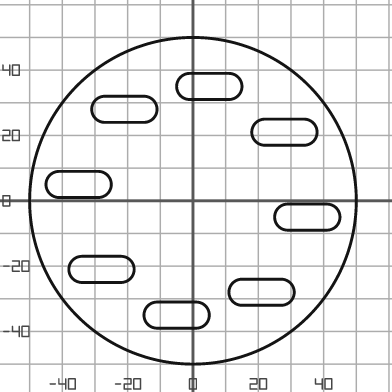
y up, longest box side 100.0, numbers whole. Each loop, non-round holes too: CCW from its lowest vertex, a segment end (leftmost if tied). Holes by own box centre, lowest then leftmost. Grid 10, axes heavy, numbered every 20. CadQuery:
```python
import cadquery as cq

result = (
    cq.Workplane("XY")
    .moveTo(0.0, 0.0)
    .circle(50.0)
    .moveTo(-11.0, -39.0)
    .lineTo(1.0, -39.0)
    .threePointArc((5.0, -35.0), (1.0, -31.0))
    .lineTo(-11.0, -31.0)
    .threePointArc((-15.0, -35.0), (-11.0, -39.0))
    .close()
    .moveTo(15.0, -32.0)
    .lineTo(27.0, -32.0)
    .threePointArc((31.0, -28.0), (27.0, -24.0))
    .lineTo(15.0, -24.0)
    .threePointArc((11.0, -28.0), (15.0, -32.0))
    .close()
    .moveTo(-34.0, -25.0)
    .lineTo(-22.0, -25.0)
    .threePointArc((-18.0, -21.0), (-22.0, -17.0))
    .lineTo(-34.0, -17.0)
    .threePointArc((-38.0, -21.0), (-34.0, -25.0))
    .close()
    .moveTo(29.0, -9.0)
    .lineTo(41.0, -9.0)
    .threePointArc((45.0, -5.0), (41.0, -1.0))
    .lineTo(29.0, -1.0)
    .threePointArc((25.0, -5.0), (29.0, -9.0))
    .close()
    .moveTo(-41.0, 1.0)
    .lineTo(-29.0, 1.0)
    .threePointArc((-25.0, 5.0), (-29.0, 9.0))
    .lineTo(-41.0, 9.0)
    .threePointArc((-45.0, 5.0), (-41.0, 1.0))
    .close()
    .moveTo(22.0, 17.0)
    .lineTo(34.0, 17.0)
    .threePointArc((38.0, 21.0), (34.0, 25.0))
    .lineTo(22.0, 25.0)
    .threePointArc((18.0, 21.0), (22.0, 17.0))
    .close()
    .moveTo(-27.0, 24.0)
    .lineTo(-15.0, 24.0)
    .threePointArc((-11.0, 28.0), (-15.0, 32.0))
    .lineTo(-27.0, 32.0)
    .threePointArc((-31.0, 28.0), (-27.0, 24.0))
    .close()
    .moveTo(-1.0, 31.0)
    .lineTo(11.0, 31.0)
    .threePointArc((15.0, 35.0), (11.0, 39.0))
    .lineTo(-1.0, 39.0)
    .threePointArc((-5.0, 35.0), (-1.0, 31.0))
    .close()
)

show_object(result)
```